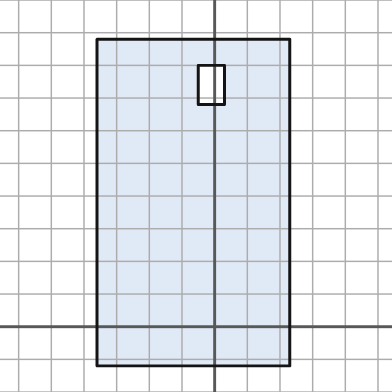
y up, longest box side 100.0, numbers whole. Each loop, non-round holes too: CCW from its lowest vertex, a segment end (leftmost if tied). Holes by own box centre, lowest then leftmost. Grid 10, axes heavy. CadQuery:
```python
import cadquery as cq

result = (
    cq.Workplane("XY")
    .moveTo(-36.0, -12.0)
    .lineTo(23.0, -12.0)
    .lineTo(23.0, 88.0)
    .lineTo(-36.0, 88.0)
    .close()
    .moveTo(-5.0, 68.0)
    .lineTo(3.0, 68.0)
    .lineTo(3.0, 80.0)
    .lineTo(-5.0, 80.0)
    .close()
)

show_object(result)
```